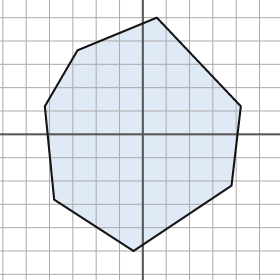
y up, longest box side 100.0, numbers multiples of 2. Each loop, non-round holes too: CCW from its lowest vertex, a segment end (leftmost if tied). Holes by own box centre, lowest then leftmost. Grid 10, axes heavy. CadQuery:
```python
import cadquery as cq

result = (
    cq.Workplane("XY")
    .moveTo(-4.0, -50.0)
    .lineTo(38.0, -22.0)
    .lineTo(42.0, 12.0)
    .lineTo(6.0, 50.0)
    .lineTo(-28.0, 36.0)
    .lineTo(-42.0, 12.0)
    .lineTo(-38.0, -28.0)
    .close()
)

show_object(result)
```